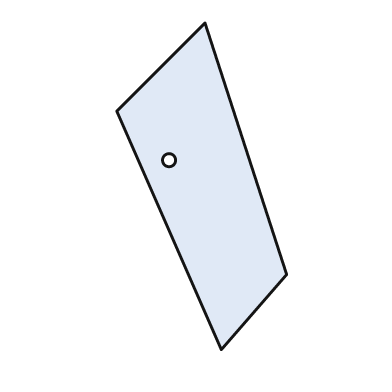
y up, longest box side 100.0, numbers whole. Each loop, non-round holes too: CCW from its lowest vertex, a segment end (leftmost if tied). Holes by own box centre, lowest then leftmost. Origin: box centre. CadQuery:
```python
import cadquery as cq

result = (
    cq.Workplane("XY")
    .moveTo(6.0, -50.0)
    .lineTo(26.0, -27.0)
    .lineTo(1.0, 50.0)
    .lineTo(-26.0, 23.0)
    .close()
    .moveTo(-10.0, 8.0)
    .circle(2.0)
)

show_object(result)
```